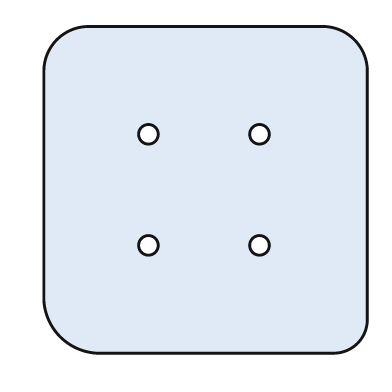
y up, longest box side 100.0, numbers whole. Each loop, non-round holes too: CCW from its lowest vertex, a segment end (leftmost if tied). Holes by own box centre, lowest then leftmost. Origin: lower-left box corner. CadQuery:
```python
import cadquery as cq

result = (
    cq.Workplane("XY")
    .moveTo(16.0, 0.0)
    .lineTo(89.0, 0.0)
    .threePointArc((96.0, 3.0), (99.0, 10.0))
    .lineTo(99.0, 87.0)
    .threePointArc((95.0, 96.0), (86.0, 100.0))
    .lineTo(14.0, 100.0)
    .threePointArc((4.0, 96.0), (0.0, 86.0))
    .lineTo(0.0, 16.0)
    .threePointArc((5.0, 5.0), (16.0, 0.0))
    .close()
    .moveTo(32.0, 33.0)
    .circle(3.0)
    .moveTo(66.0, 33.0)
    .circle(3.0)
    .moveTo(32.0, 67.0)
    .circle(3.0)
    .moveTo(66.0, 67.0)
    .circle(3.0)
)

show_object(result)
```